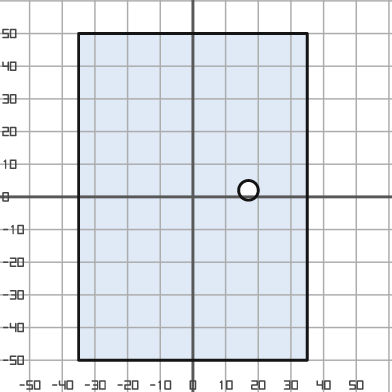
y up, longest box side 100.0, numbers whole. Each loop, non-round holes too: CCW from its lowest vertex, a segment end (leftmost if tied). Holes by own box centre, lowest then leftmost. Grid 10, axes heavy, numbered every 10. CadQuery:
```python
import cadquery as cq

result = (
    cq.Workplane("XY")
    .moveTo(-35.0, -50.0)
    .lineTo(35.0, -50.0)
    .lineTo(35.0, 50.0)
    .lineTo(-35.0, 50.0)
    .close()
    .moveTo(17.0, 2.0)
    .circle(3.0)
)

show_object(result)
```